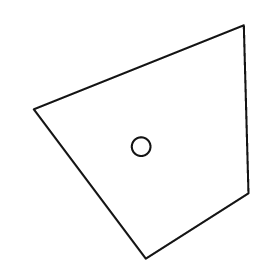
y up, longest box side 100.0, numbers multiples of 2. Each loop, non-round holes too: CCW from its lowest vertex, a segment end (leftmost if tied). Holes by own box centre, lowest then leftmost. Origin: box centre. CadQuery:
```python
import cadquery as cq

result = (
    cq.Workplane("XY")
    .moveTo(2.0, -50.0)
    .lineTo(46.0, -22.0)
    .lineTo(44.0, 50.0)
    .lineTo(-46.0, 14.0)
    .close()
    .moveTo(0.0, -2.0)
    .circle(4.0)
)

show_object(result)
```